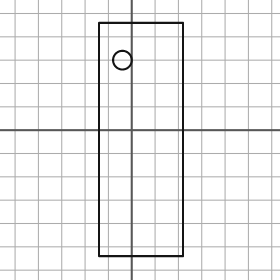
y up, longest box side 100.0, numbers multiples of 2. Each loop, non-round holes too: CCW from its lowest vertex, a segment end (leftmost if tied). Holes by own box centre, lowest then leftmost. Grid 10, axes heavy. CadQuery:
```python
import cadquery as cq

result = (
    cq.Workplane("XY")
    .moveTo(-14.0, -54.0)
    .lineTo(22.0, -54.0)
    .lineTo(22.0, 46.0)
    .lineTo(-14.0, 46.0)
    .close()
    .moveTo(-4.0, 30.0)
    .circle(4.0)
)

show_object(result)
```